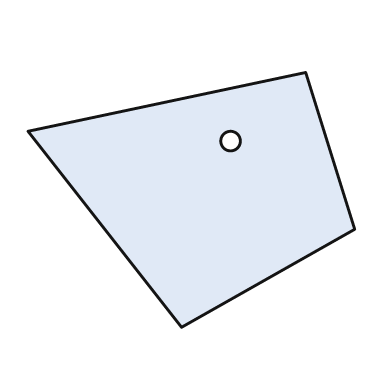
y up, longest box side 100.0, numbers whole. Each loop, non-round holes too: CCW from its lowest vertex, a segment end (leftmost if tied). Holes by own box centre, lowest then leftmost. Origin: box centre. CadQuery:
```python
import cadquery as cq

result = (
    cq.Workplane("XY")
    .moveTo(-3.0, -39.0)
    .lineTo(50.0, -9.0)
    .lineTo(35.0, 39.0)
    .lineTo(-50.0, 21.0)
    .close()
    .moveTo(12.0, 18.0)
    .circle(3.0)
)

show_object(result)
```